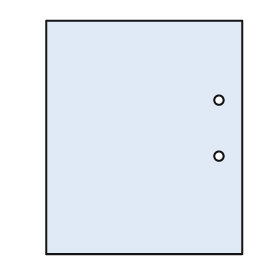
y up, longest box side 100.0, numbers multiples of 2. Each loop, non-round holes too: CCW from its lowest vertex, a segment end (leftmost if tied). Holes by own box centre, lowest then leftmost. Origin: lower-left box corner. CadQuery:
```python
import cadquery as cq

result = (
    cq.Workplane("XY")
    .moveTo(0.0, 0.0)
    .lineTo(84.0, 0.0)
    .lineTo(84.0, 100.0)
    .lineTo(0.0, 100.0)
    .close()
    .moveTo(74.0, 42.0)
    .circle(2.0)
    .moveTo(74.0, 66.0)
    .circle(2.0)
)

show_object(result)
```